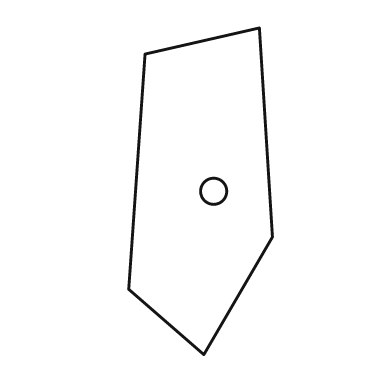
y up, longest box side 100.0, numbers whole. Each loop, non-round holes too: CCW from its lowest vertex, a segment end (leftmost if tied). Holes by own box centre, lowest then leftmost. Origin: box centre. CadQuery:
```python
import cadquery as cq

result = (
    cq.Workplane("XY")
    .moveTo(1.0, -50.0)
    .lineTo(22.0, -14.0)
    .lineTo(18.0, 50.0)
    .lineTo(-17.0, 42.0)
    .lineTo(-22.0, -30.0)
    .close()
    .moveTo(4.0, 0.0)
    .circle(4.0)
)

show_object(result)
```